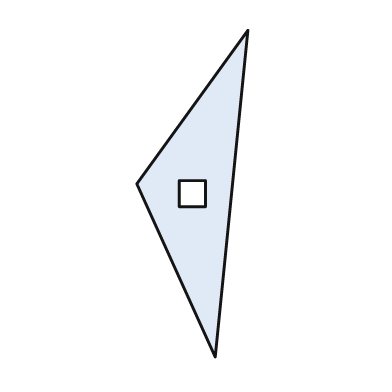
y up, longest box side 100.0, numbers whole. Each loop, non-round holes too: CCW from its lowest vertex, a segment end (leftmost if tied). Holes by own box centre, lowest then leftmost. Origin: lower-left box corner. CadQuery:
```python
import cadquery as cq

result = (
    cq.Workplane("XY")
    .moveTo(24.0, 0.0)
    .lineTo(34.0, 100.0)
    .lineTo(0.0, 53.0)
    .close()
    .moveTo(13.0, 46.0)
    .lineTo(21.0, 46.0)
    .lineTo(21.0, 54.0)
    .lineTo(13.0, 54.0)
    .close()
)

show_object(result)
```